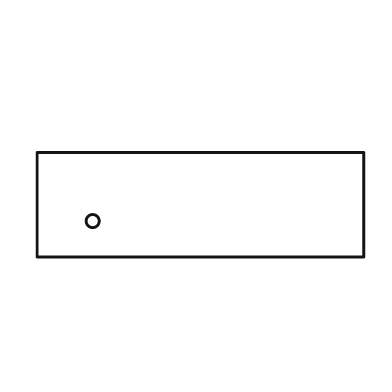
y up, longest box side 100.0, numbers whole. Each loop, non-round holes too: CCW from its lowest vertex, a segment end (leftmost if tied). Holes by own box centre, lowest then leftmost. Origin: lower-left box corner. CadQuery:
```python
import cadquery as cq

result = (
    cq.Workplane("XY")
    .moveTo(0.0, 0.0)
    .lineTo(100.0, 0.0)
    .lineTo(100.0, 32.0)
    .lineTo(0.0, 32.0)
    .close()
    .moveTo(17.0, 11.0)
    .circle(2.0)
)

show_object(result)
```